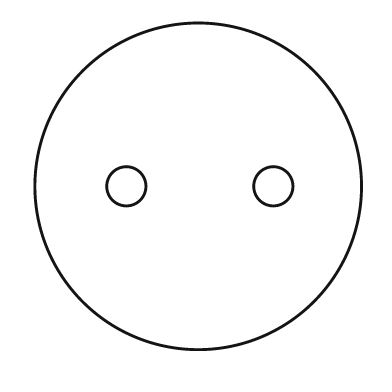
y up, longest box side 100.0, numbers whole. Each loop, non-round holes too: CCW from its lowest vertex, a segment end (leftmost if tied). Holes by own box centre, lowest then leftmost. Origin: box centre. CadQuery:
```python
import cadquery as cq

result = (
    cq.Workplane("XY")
    .moveTo(0.0, 0.0)
    .circle(50.0)
    .moveTo(-22.0, 0.0)
    .circle(6.0)
    .moveTo(23.0, 0.0)
    .circle(6.0)
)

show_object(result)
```